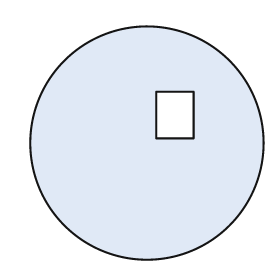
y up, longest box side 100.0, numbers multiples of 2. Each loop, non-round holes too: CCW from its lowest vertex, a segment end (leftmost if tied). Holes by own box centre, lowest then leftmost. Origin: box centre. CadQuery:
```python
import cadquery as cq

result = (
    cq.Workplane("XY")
    .moveTo(0.0, 0.0)
    .circle(50.0)
    .moveTo(4.0, 2.0)
    .lineTo(20.0, 2.0)
    .lineTo(20.0, 22.0)
    .lineTo(4.0, 22.0)
    .close()
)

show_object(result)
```